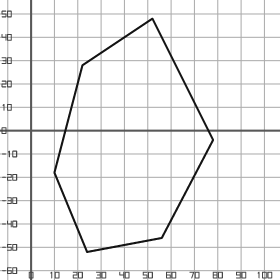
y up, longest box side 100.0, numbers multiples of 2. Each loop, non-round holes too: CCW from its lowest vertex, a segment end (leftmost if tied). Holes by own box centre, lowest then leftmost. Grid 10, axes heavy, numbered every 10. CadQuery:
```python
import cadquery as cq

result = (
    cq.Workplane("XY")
    .moveTo(24.0, -52.0)
    .lineTo(56.0, -46.0)
    .lineTo(78.0, -4.0)
    .lineTo(52.0, 48.0)
    .lineTo(22.0, 28.0)
    .lineTo(10.0, -18.0)
    .close()
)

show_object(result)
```